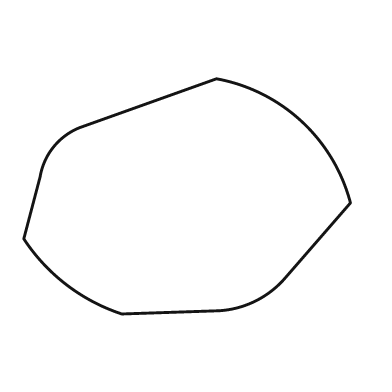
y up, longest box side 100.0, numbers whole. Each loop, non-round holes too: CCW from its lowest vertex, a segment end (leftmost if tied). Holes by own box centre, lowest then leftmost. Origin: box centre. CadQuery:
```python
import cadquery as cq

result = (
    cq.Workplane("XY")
    .moveTo(-20.0, -36.0)
    .lineTo(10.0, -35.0)
    .threePointArc((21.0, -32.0), (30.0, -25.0))
    .lineTo(50.0, -2.0)
    .threePointArc((35.0, 23.0), (9.0, 36.0))
    .lineTo(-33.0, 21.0)
    .threePointArc((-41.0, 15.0), (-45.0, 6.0))
    .lineTo(-50.0, -13.0)
    .threePointArc((-37.0, -27.0), (-20.0, -36.0))
    .close()
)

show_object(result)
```